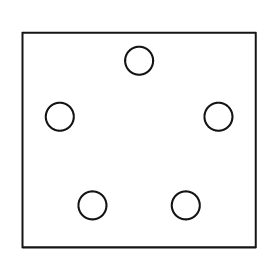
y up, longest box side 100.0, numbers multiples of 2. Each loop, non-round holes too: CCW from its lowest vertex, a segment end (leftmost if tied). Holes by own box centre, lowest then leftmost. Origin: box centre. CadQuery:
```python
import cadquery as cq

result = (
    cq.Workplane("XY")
    .moveTo(-50.0, -46.0)
    .lineTo(50.0, -46.0)
    .lineTo(50.0, 46.0)
    .lineTo(-50.0, 46.0)
    .close()
    .moveTo(-20.0, -28.0)
    .circle(6.0)
    .moveTo(20.0, -28.0)
    .circle(6.0)
    .moveTo(-34.0, 10.0)
    .circle(6.0)
    .moveTo(34.0, 10.0)
    .circle(6.0)
    .moveTo(0.0, 34.0)
    .circle(6.0)
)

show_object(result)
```